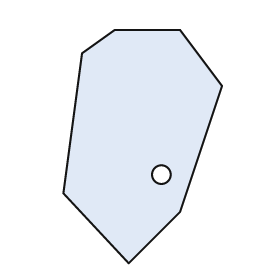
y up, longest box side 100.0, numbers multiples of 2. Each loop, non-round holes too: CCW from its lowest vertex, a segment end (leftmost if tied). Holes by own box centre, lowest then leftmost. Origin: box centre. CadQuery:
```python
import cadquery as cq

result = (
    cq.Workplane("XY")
    .moveTo(-6.0, -50.0)
    .lineTo(16.0, -28.0)
    .lineTo(34.0, 26.0)
    .lineTo(16.0, 50.0)
    .lineTo(-12.0, 50.0)
    .lineTo(-26.0, 40.0)
    .lineTo(-34.0, -20.0)
    .close()
    .moveTo(8.0, -12.0)
    .circle(4.0)
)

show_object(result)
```